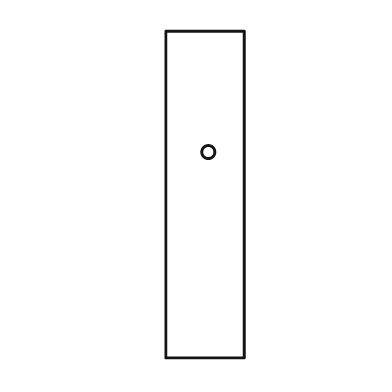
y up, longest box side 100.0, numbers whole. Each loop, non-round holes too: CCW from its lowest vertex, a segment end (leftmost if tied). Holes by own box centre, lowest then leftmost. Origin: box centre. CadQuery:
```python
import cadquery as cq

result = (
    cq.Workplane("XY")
    .moveTo(-12.0, -50.0)
    .lineTo(12.0, -50.0)
    .lineTo(12.0, 50.0)
    .lineTo(-12.0, 50.0)
    .close()
    .moveTo(1.0, 13.0)
    .circle(2.0)
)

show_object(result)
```